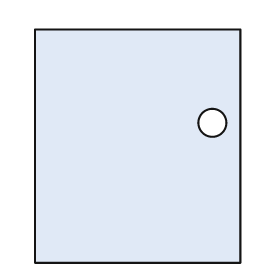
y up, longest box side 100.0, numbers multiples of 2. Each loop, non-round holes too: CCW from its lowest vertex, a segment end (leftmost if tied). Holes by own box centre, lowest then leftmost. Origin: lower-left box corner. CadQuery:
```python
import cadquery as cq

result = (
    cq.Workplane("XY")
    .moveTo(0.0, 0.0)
    .lineTo(88.0, 0.0)
    .lineTo(88.0, 100.0)
    .lineTo(0.0, 100.0)
    .close()
    .moveTo(76.0, 60.0)
    .circle(6.0)
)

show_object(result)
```